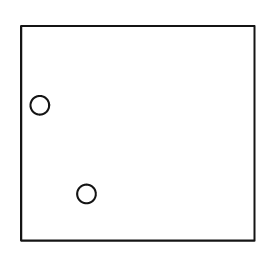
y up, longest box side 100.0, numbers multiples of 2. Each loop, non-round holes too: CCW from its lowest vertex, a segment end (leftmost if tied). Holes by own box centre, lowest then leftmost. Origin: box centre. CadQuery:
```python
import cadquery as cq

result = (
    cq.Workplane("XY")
    .moveTo(-50.0, -46.0)
    .lineTo(50.0, -46.0)
    .lineTo(50.0, 46.0)
    .lineTo(-50.0, 46.0)
    .close()
    .moveTo(-22.0, -26.0)
    .circle(4.0)
    .moveTo(-42.0, 12.0)
    .circle(4.0)
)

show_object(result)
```